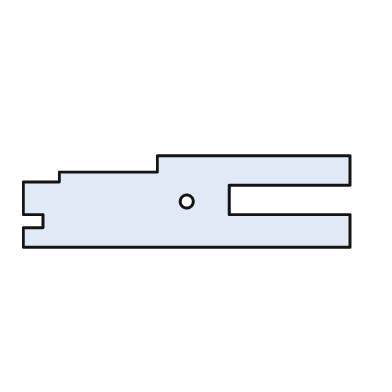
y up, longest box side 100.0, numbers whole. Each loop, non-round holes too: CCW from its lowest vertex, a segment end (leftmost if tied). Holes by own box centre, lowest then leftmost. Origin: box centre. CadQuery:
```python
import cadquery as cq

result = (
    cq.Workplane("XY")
    .moveTo(-50.0, -14.0)
    .lineTo(50.0, -14.0)
    .lineTo(50.0, -4.0)
    .lineTo(13.0, -4.0)
    .lineTo(13.0, 5.0)
    .lineTo(50.0, 5.0)
    .lineTo(50.0, 14.0)
    .lineTo(-9.0, 14.0)
    .lineTo(-9.0, 9.0)
    .lineTo(-39.0, 9.0)
    .lineTo(-39.0, 6.0)
    .lineTo(-50.0, 6.0)
    .lineTo(-50.0, -4.0)
    .lineTo(-44.0, -4.0)
    .lineTo(-44.0, -8.0)
    .lineTo(-50.0, -8.0)
    .close()
    .moveTo(0.0, 0.0)
    .circle(2.0)
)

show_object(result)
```